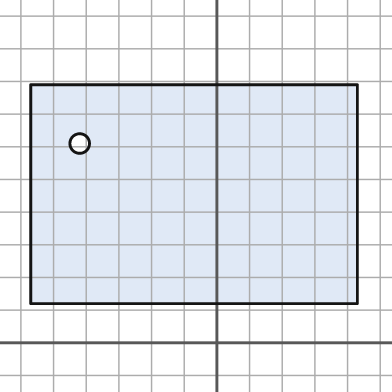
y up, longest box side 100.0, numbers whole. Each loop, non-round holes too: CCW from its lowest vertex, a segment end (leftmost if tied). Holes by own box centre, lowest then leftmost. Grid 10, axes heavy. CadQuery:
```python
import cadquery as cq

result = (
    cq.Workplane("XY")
    .moveTo(-57.0, 12.0)
    .lineTo(43.0, 12.0)
    .lineTo(43.0, 79.0)
    .lineTo(-57.0, 79.0)
    .close()
    .moveTo(-42.0, 61.0)
    .circle(3.0)
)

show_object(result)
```